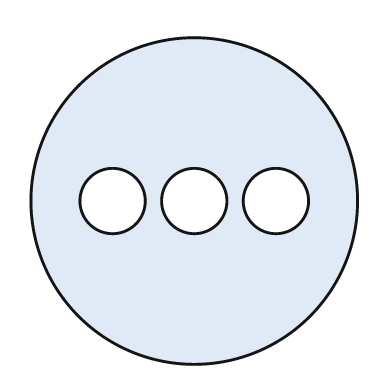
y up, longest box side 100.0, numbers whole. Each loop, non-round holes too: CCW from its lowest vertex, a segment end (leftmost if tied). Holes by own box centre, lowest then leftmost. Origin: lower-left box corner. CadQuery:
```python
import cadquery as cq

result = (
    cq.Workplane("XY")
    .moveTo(50.0, 50.0)
    .circle(50.0)
    .moveTo(25.0, 50.0)
    .circle(10.0)
    .moveTo(50.0, 50.0)
    .circle(10.0)
    .moveTo(75.0, 50.0)
    .circle(10.0)
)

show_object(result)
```